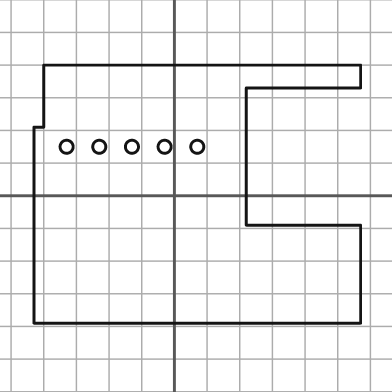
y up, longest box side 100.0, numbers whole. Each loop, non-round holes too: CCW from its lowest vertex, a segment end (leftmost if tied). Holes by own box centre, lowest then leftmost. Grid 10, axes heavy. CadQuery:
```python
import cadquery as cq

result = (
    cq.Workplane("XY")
    .moveTo(-43.0, -39.0)
    .lineTo(57.0, -39.0)
    .lineTo(57.0, -9.0)
    .lineTo(22.0, -9.0)
    .lineTo(22.0, 33.0)
    .lineTo(57.0, 33.0)
    .lineTo(57.0, 40.0)
    .lineTo(-40.0, 40.0)
    .lineTo(-40.0, 21.0)
    .lineTo(-43.0, 21.0)
    .close()
    .moveTo(-33.0, 15.0)
    .circle(2.0)
    .moveTo(-23.0, 15.0)
    .circle(2.0)
    .moveTo(-13.0, 15.0)
    .circle(2.0)
    .moveTo(-3.0, 15.0)
    .circle(2.0)
    .moveTo(7.0, 15.0)
    .circle(2.0)
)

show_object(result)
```